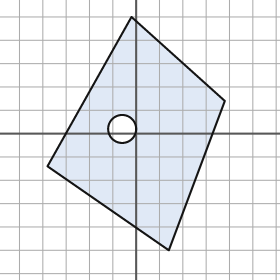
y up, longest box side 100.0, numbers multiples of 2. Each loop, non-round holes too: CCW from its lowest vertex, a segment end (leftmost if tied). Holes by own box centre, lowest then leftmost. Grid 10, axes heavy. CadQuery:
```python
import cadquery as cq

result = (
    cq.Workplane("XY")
    .moveTo(14.0, -50.0)
    .lineTo(38.0, 14.0)
    .lineTo(-2.0, 50.0)
    .lineTo(-38.0, -14.0)
    .close()
    .moveTo(-6.0, 2.0)
    .circle(6.0)
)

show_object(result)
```